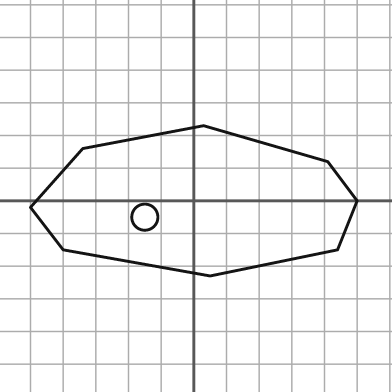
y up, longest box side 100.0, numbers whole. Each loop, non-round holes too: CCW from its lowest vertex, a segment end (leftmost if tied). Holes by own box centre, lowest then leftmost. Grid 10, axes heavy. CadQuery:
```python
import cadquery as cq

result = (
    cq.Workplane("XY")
    .moveTo(5.0, -23.0)
    .lineTo(44.0, -15.0)
    .lineTo(50.0, 0.0)
    .lineTo(41.0, 12.0)
    .lineTo(3.0, 23.0)
    .lineTo(-34.0, 16.0)
    .lineTo(-50.0, -2.0)
    .lineTo(-40.0, -15.0)
    .close()
    .moveTo(-15.0, -5.0)
    .circle(4.0)
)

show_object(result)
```